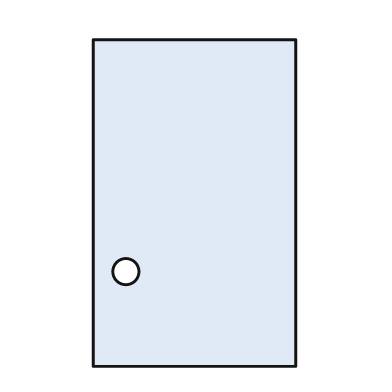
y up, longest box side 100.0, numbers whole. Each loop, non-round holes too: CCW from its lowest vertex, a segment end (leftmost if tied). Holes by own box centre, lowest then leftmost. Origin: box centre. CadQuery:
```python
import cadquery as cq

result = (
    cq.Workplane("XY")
    .moveTo(-31.0, -50.0)
    .lineTo(31.0, -50.0)
    .lineTo(31.0, 50.0)
    .lineTo(-31.0, 50.0)
    .close()
    .moveTo(-21.0, -21.0)
    .circle(4.0)
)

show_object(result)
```